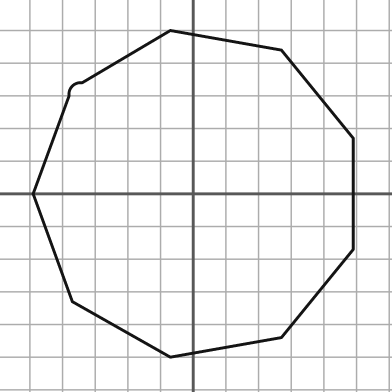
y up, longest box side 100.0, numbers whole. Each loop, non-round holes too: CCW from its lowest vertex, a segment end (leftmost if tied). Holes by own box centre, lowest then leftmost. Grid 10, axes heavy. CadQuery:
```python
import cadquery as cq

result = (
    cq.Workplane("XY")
    .moveTo(-7.0, -50.0)
    .lineTo(27.0, -44.0)
    .lineTo(49.0, -17.0)
    .lineTo(49.0, 17.0)
    .lineTo(27.0, 44.0)
    .lineTo(-7.0, 50.0)
    .lineTo(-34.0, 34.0)
    .threePointArc((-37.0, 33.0), (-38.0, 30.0))
    .lineTo(-49.0, 0.0)
    .lineTo(-37.0, -33.0)
    .close()
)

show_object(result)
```